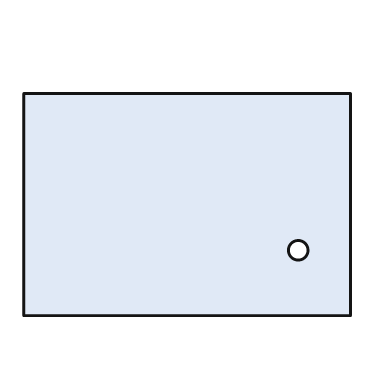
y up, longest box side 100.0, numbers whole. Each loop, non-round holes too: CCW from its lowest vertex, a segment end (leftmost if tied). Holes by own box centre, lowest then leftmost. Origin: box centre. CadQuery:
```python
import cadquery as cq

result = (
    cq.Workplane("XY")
    .moveTo(-50.0, -34.0)
    .lineTo(50.0, -34.0)
    .lineTo(50.0, 34.0)
    .lineTo(-50.0, 34.0)
    .close()
    .moveTo(34.0, -14.0)
    .circle(3.0)
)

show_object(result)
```